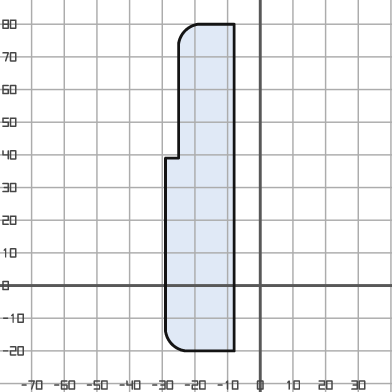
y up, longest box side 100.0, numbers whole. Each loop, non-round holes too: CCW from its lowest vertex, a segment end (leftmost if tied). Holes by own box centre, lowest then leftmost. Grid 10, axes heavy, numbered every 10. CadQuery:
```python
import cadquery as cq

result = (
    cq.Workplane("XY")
    .moveTo(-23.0, -20.0)
    .lineTo(-8.0, -20.0)
    .lineTo(-8.0, 80.0)
    .lineTo(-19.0, 80.0)
    .threePointArc((-23.0, 78.0), (-25.0, 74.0))
    .lineTo(-25.0, 39.0)
    .lineTo(-29.0, 39.0)
    .lineTo(-29.0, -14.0)
    .threePointArc((-27.0, -18.0), (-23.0, -20.0))
    .close()
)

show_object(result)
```